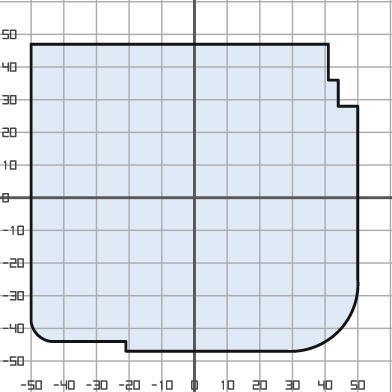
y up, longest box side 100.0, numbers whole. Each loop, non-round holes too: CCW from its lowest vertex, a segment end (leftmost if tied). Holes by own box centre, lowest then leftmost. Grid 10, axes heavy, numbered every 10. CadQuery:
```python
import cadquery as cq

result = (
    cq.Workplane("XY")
    .moveTo(-21.0, -47.0)
    .lineTo(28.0, -47.0)
    .threePointArc((44.0, -41.0), (50.0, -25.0))
    .lineTo(50.0, 28.0)
    .lineTo(44.0, 28.0)
    .lineTo(44.0, 36.0)
    .lineTo(41.0, 36.0)
    .lineTo(41.0, 47.0)
    .lineTo(-50.0, 47.0)
    .lineTo(-50.0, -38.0)
    .threePointArc((-48.0, -42.0), (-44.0, -44.0))
    .lineTo(-21.0, -44.0)
    .close()
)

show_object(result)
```